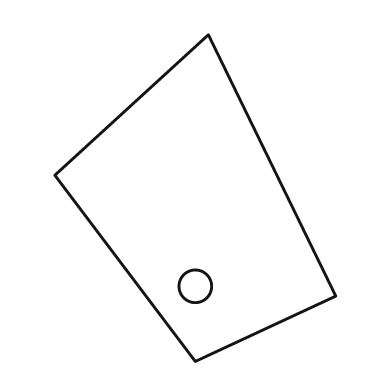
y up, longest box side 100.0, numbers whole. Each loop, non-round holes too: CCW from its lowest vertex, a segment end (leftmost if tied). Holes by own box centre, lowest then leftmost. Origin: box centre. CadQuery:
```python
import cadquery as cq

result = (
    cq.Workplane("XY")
    .moveTo(0.0, -50.0)
    .lineTo(43.0, -30.0)
    .lineTo(4.0, 50.0)
    .lineTo(-43.0, 7.0)
    .close()
    .moveTo(0.0, -27.0)
    .circle(5.0)
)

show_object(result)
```